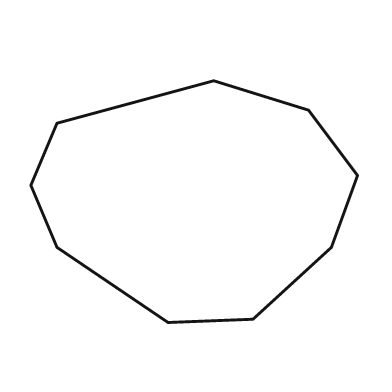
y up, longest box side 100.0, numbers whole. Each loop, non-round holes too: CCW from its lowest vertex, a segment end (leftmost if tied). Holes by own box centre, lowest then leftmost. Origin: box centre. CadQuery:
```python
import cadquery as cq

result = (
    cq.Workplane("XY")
    .moveTo(-8.0, -37.0)
    .lineTo(18.0, -36.0)
    .lineTo(42.0, -14.0)
    .lineTo(50.0, 8.0)
    .lineTo(35.0, 28.0)
    .lineTo(6.0, 37.0)
    .lineTo(-42.0, 24.0)
    .lineTo(-50.0, 5.0)
    .lineTo(-42.0, -14.0)
    .close()
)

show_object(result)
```